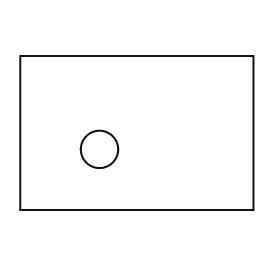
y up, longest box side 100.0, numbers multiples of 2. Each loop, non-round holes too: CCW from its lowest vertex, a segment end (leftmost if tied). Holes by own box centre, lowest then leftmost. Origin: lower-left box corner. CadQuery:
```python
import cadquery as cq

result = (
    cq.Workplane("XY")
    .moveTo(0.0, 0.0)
    .lineTo(100.0, 0.0)
    .lineTo(100.0, 66.0)
    .lineTo(0.0, 66.0)
    .close()
    .moveTo(34.0, 26.0)
    .circle(8.0)
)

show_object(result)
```